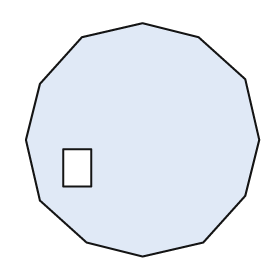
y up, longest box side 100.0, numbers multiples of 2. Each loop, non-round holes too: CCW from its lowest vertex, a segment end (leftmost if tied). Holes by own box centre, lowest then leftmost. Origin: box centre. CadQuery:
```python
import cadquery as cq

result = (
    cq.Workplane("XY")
    .moveTo(0.0, -50.0)
    .lineTo(26.0, -44.0)
    .lineTo(44.0, -24.0)
    .lineTo(50.0, 0.0)
    .lineTo(44.0, 26.0)
    .lineTo(24.0, 44.0)
    .lineTo(0.0, 50.0)
    .lineTo(-26.0, 44.0)
    .lineTo(-44.0, 24.0)
    .lineTo(-50.0, 0.0)
    .lineTo(-44.0, -26.0)
    .lineTo(-24.0, -44.0)
    .close()
    .moveTo(-34.0, -20.0)
    .lineTo(-22.0, -20.0)
    .lineTo(-22.0, -4.0)
    .lineTo(-34.0, -4.0)
    .close()
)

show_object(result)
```